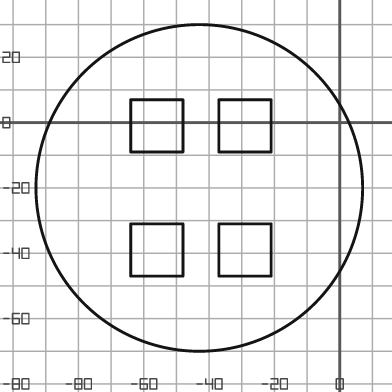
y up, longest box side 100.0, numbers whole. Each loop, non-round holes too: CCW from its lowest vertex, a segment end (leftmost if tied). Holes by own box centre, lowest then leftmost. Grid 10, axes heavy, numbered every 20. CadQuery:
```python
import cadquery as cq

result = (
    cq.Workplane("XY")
    .moveTo(-43.0, -20.0)
    .circle(50.0)
    .moveTo(-64.0, -47.0)
    .lineTo(-48.0, -47.0)
    .lineTo(-48.0, -31.0)
    .lineTo(-64.0, -31.0)
    .close()
    .moveTo(-37.0, -47.0)
    .lineTo(-21.0, -47.0)
    .lineTo(-21.0, -31.0)
    .lineTo(-37.0, -31.0)
    .close()
    .moveTo(-64.0, -9.0)
    .lineTo(-48.0, -9.0)
    .lineTo(-48.0, 7.0)
    .lineTo(-64.0, 7.0)
    .close()
    .moveTo(-37.0, -9.0)
    .lineTo(-21.0, -9.0)
    .lineTo(-21.0, 7.0)
    .lineTo(-37.0, 7.0)
    .close()
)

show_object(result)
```